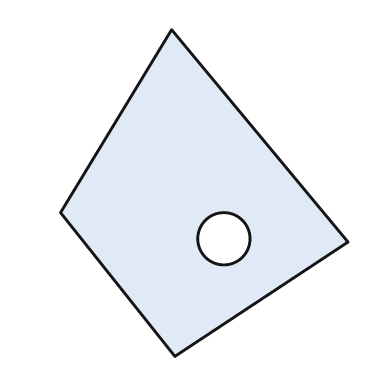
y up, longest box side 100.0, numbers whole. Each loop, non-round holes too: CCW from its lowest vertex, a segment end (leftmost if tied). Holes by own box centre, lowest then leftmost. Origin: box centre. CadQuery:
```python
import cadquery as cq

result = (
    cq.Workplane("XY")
    .moveTo(-9.0, -50.0)
    .lineTo(44.0, -15.0)
    .lineTo(-10.0, 50.0)
    .lineTo(-44.0, -6.0)
    .close()
    .moveTo(6.0, -14.0)
    .circle(8.0)
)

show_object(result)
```